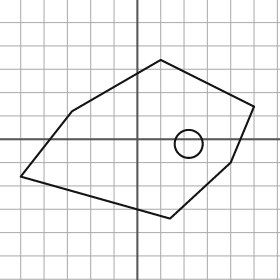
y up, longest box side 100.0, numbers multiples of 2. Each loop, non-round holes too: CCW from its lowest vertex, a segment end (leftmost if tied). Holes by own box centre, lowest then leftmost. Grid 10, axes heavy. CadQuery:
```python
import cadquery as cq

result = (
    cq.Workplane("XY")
    .moveTo(14.0, -34.0)
    .lineTo(40.0, -10.0)
    .lineTo(50.0, 14.0)
    .lineTo(10.0, 34.0)
    .lineTo(-28.0, 12.0)
    .lineTo(-50.0, -16.0)
    .close()
    .moveTo(22.0, -2.0)
    .circle(6.0)
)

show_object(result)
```